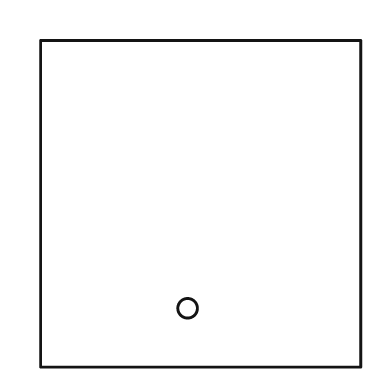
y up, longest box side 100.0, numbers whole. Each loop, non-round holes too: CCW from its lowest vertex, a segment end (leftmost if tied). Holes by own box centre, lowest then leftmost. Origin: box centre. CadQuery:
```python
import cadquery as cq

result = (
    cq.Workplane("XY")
    .moveTo(-49.0, -50.0)
    .lineTo(49.0, -50.0)
    .lineTo(49.0, 50.0)
    .lineTo(-49.0, 50.0)
    .close()
    .moveTo(-4.0, -32.0)
    .circle(3.0)
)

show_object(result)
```